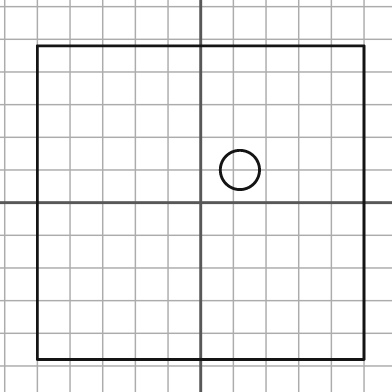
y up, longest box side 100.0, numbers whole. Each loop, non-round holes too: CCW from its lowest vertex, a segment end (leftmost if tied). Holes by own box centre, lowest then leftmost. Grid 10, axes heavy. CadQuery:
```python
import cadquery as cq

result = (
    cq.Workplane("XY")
    .moveTo(-50.0, -48.0)
    .lineTo(50.0, -48.0)
    .lineTo(50.0, 48.0)
    .lineTo(-50.0, 48.0)
    .close()
    .moveTo(12.0, 10.0)
    .circle(6.0)
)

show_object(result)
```